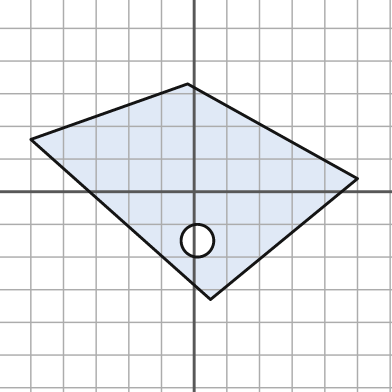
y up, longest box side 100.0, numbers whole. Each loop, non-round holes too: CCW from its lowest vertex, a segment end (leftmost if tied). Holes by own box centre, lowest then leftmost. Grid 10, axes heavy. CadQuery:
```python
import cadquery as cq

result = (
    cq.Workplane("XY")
    .moveTo(5.0, -33.0)
    .lineTo(50.0, 4.0)
    .lineTo(-2.0, 33.0)
    .lineTo(-50.0, 16.0)
    .close()
    .moveTo(1.0, -15.0)
    .circle(5.0)
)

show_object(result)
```